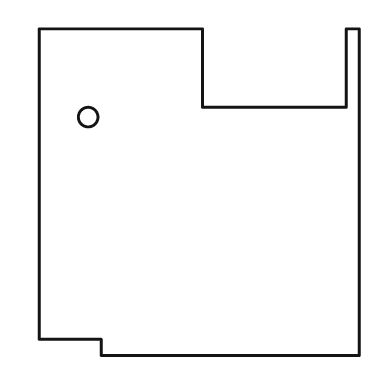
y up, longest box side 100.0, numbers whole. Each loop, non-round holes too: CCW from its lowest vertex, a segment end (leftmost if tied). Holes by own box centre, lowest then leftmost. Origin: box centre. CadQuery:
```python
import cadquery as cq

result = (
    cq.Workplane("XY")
    .moveTo(-30.0, -50.0)
    .lineTo(49.0, -50.0)
    .lineTo(49.0, 50.0)
    .lineTo(45.0, 50.0)
    .lineTo(45.0, 26.0)
    .lineTo(1.0, 26.0)
    .lineTo(1.0, 50.0)
    .lineTo(-49.0, 50.0)
    .lineTo(-49.0, -45.0)
    .lineTo(-30.0, -45.0)
    .close()
    .moveTo(-34.0, 23.0)
    .circle(3.0)
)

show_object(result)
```